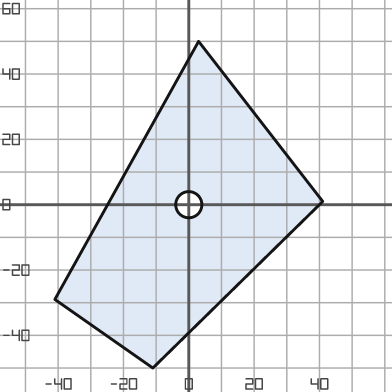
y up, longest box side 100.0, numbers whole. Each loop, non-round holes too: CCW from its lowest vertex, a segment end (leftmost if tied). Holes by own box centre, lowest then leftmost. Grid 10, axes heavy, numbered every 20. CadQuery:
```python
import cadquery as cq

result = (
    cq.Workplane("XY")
    .moveTo(-11.0, -50.0)
    .lineTo(41.0, 1.0)
    .lineTo(3.0, 50.0)
    .lineTo(-41.0, -29.0)
    .close()
    .moveTo(0.0, 0.0)
    .circle(4.0)
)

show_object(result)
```